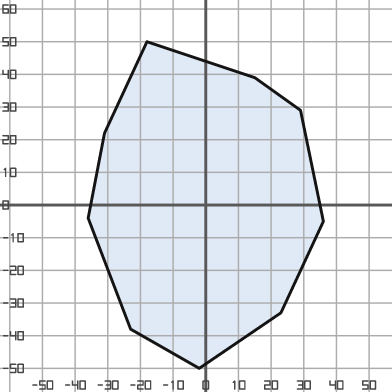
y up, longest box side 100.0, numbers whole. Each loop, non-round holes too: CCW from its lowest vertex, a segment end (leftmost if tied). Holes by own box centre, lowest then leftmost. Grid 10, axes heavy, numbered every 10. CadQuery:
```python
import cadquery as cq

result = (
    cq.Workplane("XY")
    .moveTo(-2.0, -50.0)
    .lineTo(23.0, -33.0)
    .lineTo(36.0, -5.0)
    .lineTo(29.0, 29.0)
    .lineTo(15.0, 39.0)
    .lineTo(-18.0, 50.0)
    .lineTo(-31.0, 22.0)
    .lineTo(-36.0, -4.0)
    .lineTo(-23.0, -38.0)
    .close()
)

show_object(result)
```